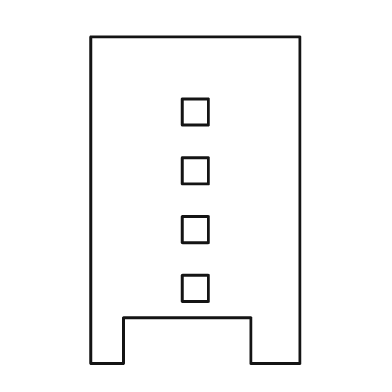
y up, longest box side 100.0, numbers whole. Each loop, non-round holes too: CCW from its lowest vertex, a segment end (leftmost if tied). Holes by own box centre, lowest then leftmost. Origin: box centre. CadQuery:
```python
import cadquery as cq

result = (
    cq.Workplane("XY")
    .moveTo(-32.0, -50.0)
    .lineTo(-22.0, -50.0)
    .lineTo(-22.0, -36.0)
    .lineTo(17.0, -36.0)
    .lineTo(17.0, -50.0)
    .lineTo(32.0, -50.0)
    .lineTo(32.0, 50.0)
    .lineTo(-32.0, 50.0)
    .close()
    .moveTo(-4.0, -31.0)
    .lineTo(4.0, -31.0)
    .lineTo(4.0, -23.0)
    .lineTo(-4.0, -23.0)
    .close()
    .moveTo(-4.0, -13.0)
    .lineTo(4.0, -13.0)
    .lineTo(4.0, -5.0)
    .lineTo(-4.0, -5.0)
    .close()
    .moveTo(-4.0, 5.0)
    .lineTo(4.0, 5.0)
    .lineTo(4.0, 13.0)
    .lineTo(-4.0, 13.0)
    .close()
    .moveTo(-4.0, 23.0)
    .lineTo(4.0, 23.0)
    .lineTo(4.0, 31.0)
    .lineTo(-4.0, 31.0)
    .close()
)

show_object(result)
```